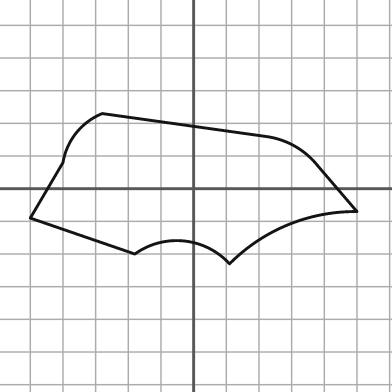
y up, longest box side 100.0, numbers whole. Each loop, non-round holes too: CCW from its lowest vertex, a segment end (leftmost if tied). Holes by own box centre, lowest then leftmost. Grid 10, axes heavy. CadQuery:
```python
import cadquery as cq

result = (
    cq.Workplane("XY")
    .moveTo(11.0, -23.0)
    .threePointArc((29.0, -11.0), (50.0, -7.0))
    .lineTo(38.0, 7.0)
    .threePointArc((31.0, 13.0), (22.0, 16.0))
    .lineTo(-28.0, 23.0)
    .threePointArc((-36.0, 17.0), (-40.0, 8.0))
    .lineTo(-50.0, -9.0)
    .lineTo(-18.0, -20.0)
    .threePointArc((-3.0, -16.0), (11.0, -23.0))
    .close()
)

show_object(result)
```